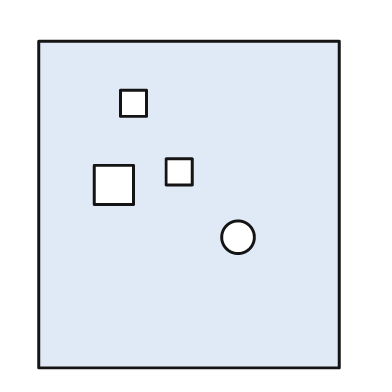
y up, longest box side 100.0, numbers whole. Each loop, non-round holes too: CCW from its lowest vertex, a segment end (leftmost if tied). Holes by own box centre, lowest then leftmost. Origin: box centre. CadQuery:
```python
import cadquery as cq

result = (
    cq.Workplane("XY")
    .moveTo(-46.0, -50.0)
    .lineTo(46.0, -50.0)
    .lineTo(46.0, 50.0)
    .lineTo(-46.0, 50.0)
    .close()
    .moveTo(15.0, -10.0)
    .circle(5.0)
    .moveTo(-29.0, 0.0)
    .lineTo(-17.0, 0.0)
    .lineTo(-17.0, 12.0)
    .lineTo(-29.0, 12.0)
    .close()
    .moveTo(-7.0, 6.0)
    .lineTo(1.0, 6.0)
    .lineTo(1.0, 14.0)
    .lineTo(-7.0, 14.0)
    .close()
    .moveTo(-21.0, 27.0)
    .lineTo(-13.0, 27.0)
    .lineTo(-13.0, 35.0)
    .lineTo(-21.0, 35.0)
    .close()
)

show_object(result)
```